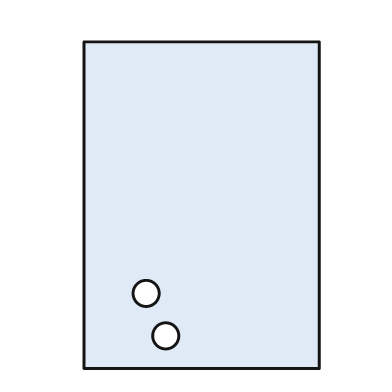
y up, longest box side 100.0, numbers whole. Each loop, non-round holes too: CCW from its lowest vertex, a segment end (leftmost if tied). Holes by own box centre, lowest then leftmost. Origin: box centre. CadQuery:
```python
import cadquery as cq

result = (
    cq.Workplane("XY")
    .moveTo(-36.0, -50.0)
    .lineTo(36.0, -50.0)
    .lineTo(36.0, 50.0)
    .lineTo(-36.0, 50.0)
    .close()
    .moveTo(-11.0, -40.0)
    .circle(4.0)
    .moveTo(-17.0, -27.0)
    .circle(4.0)
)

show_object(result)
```